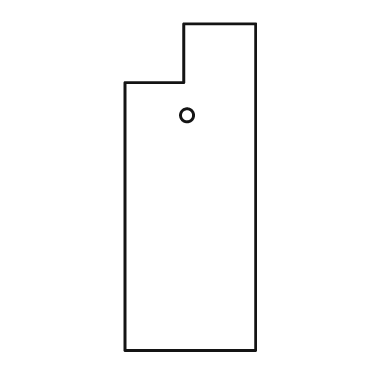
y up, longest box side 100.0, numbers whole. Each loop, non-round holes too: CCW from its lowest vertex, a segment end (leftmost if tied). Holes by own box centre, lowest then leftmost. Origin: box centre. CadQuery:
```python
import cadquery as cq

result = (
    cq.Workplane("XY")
    .moveTo(-20.0, -50.0)
    .lineTo(20.0, -50.0)
    .lineTo(20.0, 50.0)
    .lineTo(-2.0, 50.0)
    .lineTo(-2.0, 32.0)
    .lineTo(-20.0, 32.0)
    .close()
    .moveTo(-1.0, 22.0)
    .circle(2.0)
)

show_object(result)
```